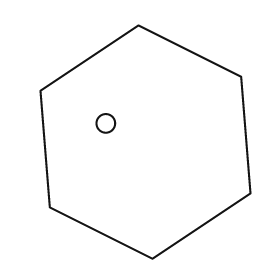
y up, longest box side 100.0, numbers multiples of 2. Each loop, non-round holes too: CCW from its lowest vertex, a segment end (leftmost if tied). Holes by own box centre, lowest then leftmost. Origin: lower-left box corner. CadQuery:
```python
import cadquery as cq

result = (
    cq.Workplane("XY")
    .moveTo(48.0, 0.0)
    .lineTo(90.0, 28.0)
    .lineTo(86.0, 78.0)
    .lineTo(42.0, 100.0)
    .lineTo(0.0, 72.0)
    .lineTo(4.0, 22.0)
    .close()
    .moveTo(28.0, 58.0)
    .circle(4.0)
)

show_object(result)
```